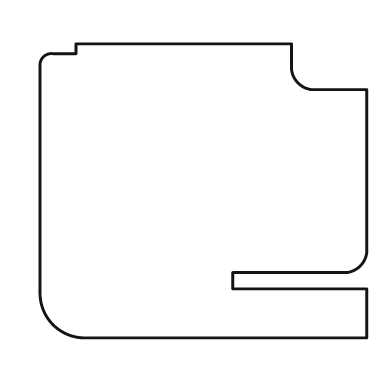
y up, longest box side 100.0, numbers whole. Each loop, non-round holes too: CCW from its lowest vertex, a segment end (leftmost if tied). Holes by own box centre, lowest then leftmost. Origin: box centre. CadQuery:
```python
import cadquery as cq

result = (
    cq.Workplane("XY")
    .moveTo(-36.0, -45.0)
    .lineTo(50.0, -45.0)
    .lineTo(50.0, -30.0)
    .lineTo(9.0, -30.0)
    .lineTo(9.0, -25.0)
    .lineTo(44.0, -25.0)
    .threePointArc((48.0, -23.0), (50.0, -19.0))
    .lineTo(50.0, 31.0)
    .lineTo(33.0, 31.0)
    .threePointArc((29.0, 33.0), (27.0, 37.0))
    .lineTo(27.0, 45.0)
    .lineTo(-39.0, 45.0)
    .lineTo(-39.0, 42.0)
    .lineTo(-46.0, 42.0)
    .threePointArc((-49.0, 41.0), (-50.0, 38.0))
    .lineTo(-50.0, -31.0)
    .threePointArc((-46.0, -41.0), (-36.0, -45.0))
    .close()
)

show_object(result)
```